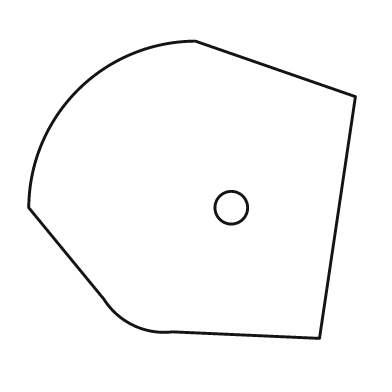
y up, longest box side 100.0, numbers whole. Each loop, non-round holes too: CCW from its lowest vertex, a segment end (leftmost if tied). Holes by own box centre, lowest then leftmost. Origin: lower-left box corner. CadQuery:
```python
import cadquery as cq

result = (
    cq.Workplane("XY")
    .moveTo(89.0, 0.0)
    .lineTo(100.0, 74.0)
    .lineTo(51.0, 91.0)
    .threePointArc((15.0, 76.0), (0.0, 40.0))
    .lineTo(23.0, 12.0)
    .threePointArc((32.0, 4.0), (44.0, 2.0))
    .close()
    .moveTo(62.0, 40.0)
    .circle(5.0)
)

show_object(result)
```